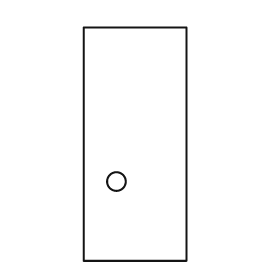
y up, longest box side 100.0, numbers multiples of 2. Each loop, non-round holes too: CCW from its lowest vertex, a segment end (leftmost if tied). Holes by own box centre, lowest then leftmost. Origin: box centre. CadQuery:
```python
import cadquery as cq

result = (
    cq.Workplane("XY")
    .moveTo(-22.0, -50.0)
    .lineTo(22.0, -50.0)
    .lineTo(22.0, 50.0)
    .lineTo(-22.0, 50.0)
    .close()
    .moveTo(-8.0, -16.0)
    .circle(4.0)
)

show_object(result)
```